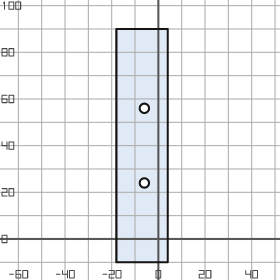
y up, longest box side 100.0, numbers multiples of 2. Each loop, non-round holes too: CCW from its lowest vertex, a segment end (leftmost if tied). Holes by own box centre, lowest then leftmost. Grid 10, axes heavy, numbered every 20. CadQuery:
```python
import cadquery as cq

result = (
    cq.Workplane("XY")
    .moveTo(-18.0, -10.0)
    .lineTo(4.0, -10.0)
    .lineTo(4.0, 90.0)
    .lineTo(-18.0, 90.0)
    .close()
    .moveTo(-6.0, 24.0)
    .circle(2.0)
    .moveTo(-6.0, 56.0)
    .circle(2.0)
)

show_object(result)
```